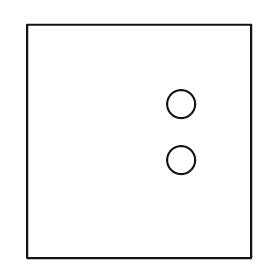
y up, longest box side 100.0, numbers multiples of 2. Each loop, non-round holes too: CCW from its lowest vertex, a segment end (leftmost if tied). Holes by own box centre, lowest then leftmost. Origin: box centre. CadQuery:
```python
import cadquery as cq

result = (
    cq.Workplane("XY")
    .moveTo(-48.0, -50.0)
    .lineTo(48.0, -50.0)
    .lineTo(48.0, 50.0)
    .lineTo(-48.0, 50.0)
    .close()
    .moveTo(18.0, -8.0)
    .circle(6.0)
    .moveTo(18.0, 16.0)
    .circle(6.0)
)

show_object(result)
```